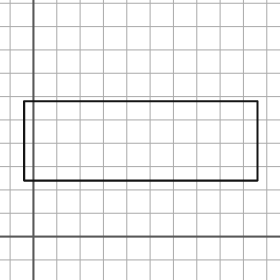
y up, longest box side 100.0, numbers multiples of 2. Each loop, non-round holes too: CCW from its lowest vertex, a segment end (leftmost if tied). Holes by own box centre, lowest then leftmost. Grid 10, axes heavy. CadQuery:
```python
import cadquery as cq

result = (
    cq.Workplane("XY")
    .moveTo(-4.0, 24.0)
    .lineTo(96.0, 24.0)
    .lineTo(96.0, 58.0)
    .lineTo(-4.0, 58.0)
    .close()
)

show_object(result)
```